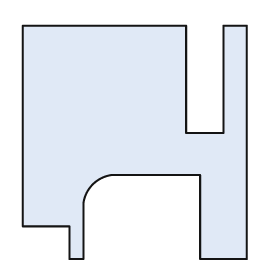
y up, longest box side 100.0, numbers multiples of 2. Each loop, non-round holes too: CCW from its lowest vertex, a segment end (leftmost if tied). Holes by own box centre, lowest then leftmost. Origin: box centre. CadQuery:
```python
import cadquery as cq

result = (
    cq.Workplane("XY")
    .moveTo(-28.0, -50.0)
    .lineTo(-22.0, -50.0)
    .lineTo(-22.0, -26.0)
    .threePointArc((-18.0, -18.0), (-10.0, -14.0))
    .lineTo(28.0, -14.0)
    .lineTo(28.0, -50.0)
    .lineTo(48.0, -50.0)
    .lineTo(48.0, 50.0)
    .lineTo(38.0, 50.0)
    .lineTo(38.0, 4.0)
    .lineTo(22.0, 4.0)
    .lineTo(22.0, 50.0)
    .lineTo(-48.0, 50.0)
    .lineTo(-48.0, -36.0)
    .lineTo(-28.0, -36.0)
    .close()
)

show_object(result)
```